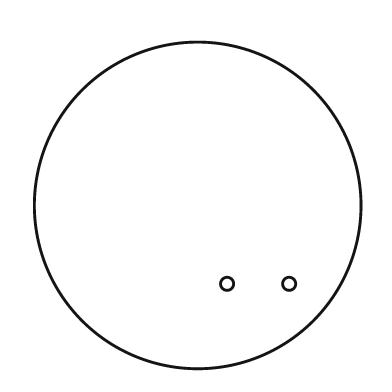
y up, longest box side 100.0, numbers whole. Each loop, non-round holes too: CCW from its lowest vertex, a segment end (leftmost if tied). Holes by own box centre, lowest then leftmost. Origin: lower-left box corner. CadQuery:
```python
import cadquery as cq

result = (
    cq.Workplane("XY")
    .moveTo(50.0, 50.0)
    .circle(50.0)
    .moveTo(59.0, 26.0)
    .circle(2.0)
    .moveTo(78.0, 26.0)
    .circle(2.0)
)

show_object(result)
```